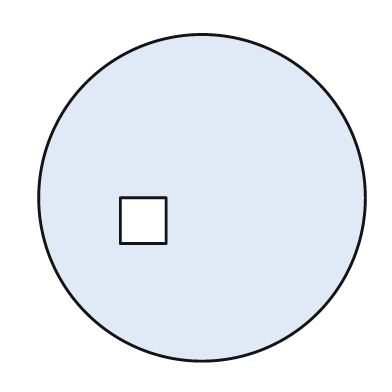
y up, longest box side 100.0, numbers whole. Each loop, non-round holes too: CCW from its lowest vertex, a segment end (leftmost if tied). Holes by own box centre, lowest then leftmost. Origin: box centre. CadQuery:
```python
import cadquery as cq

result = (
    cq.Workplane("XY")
    .moveTo(0.0, 0.0)
    .circle(50.0)
    .moveTo(-25.0, -14.0)
    .lineTo(-11.0, -14.0)
    .lineTo(-11.0, 0.0)
    .lineTo(-25.0, 0.0)
    .close()
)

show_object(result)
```